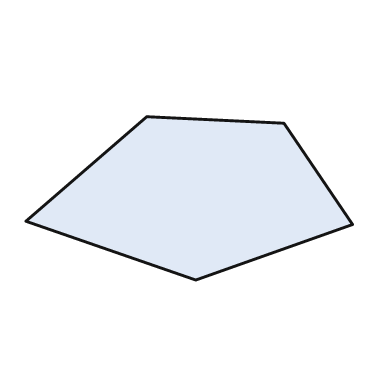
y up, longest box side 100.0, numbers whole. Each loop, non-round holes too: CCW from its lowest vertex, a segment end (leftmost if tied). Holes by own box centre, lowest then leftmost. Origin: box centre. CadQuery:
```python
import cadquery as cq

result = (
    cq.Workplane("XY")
    .moveTo(2.0, -25.0)
    .lineTo(50.0, -8.0)
    .lineTo(29.0, 23.0)
    .lineTo(-13.0, 25.0)
    .lineTo(-50.0, -7.0)
    .close()
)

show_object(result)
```